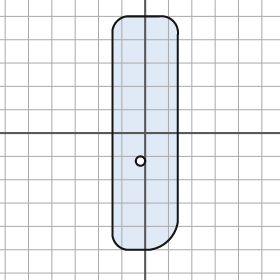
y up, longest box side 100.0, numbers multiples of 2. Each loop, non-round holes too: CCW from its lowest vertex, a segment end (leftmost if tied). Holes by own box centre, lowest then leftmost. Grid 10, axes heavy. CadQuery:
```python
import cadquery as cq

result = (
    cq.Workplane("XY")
    .moveTo(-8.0, -50.0)
    .lineTo(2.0, -50.0)
    .threePointArc((10.0, -46.0), (14.0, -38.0))
    .lineTo(14.0, 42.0)
    .threePointArc((12.0, 48.0), (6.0, 50.0))
    .lineTo(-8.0, 50.0)
    .threePointArc((-12.0, 48.0), (-14.0, 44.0))
    .lineTo(-14.0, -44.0)
    .threePointArc((-12.0, -48.0), (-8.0, -50.0))
    .close()
    .moveTo(-2.0, -12.0)
    .circle(2.0)
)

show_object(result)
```